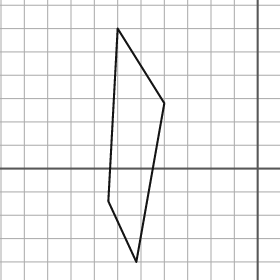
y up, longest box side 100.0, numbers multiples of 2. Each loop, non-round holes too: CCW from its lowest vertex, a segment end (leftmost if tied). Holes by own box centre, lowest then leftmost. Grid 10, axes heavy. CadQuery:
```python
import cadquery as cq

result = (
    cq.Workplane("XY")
    .moveTo(-52.0, -40.0)
    .lineTo(-40.0, 28.0)
    .lineTo(-60.0, 60.0)
    .lineTo(-64.0, -14.0)
    .close()
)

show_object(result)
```